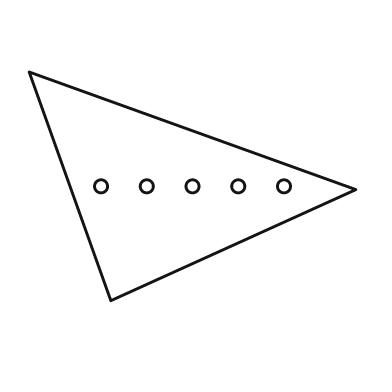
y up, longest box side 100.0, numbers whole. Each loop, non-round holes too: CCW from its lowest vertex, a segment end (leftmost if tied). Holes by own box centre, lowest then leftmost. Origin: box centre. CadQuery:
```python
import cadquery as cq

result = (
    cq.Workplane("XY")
    .moveTo(-25.0, -35.0)
    .lineTo(50.0, -1.0)
    .lineTo(-50.0, 35.0)
    .close()
    .moveTo(-28.0, 0.0)
    .circle(2.0)
    .moveTo(-14.0, 0.0)
    .circle(2.0)
    .moveTo(0.0, 0.0)
    .circle(2.0)
    .moveTo(14.0, 0.0)
    .circle(2.0)
    .moveTo(28.0, 0.0)
    .circle(2.0)
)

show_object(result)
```